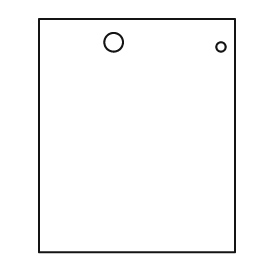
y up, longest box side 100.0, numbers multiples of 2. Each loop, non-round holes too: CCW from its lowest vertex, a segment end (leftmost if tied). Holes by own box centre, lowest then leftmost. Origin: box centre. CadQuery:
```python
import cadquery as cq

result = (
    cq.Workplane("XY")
    .moveTo(-42.0, -50.0)
    .lineTo(42.0, -50.0)
    .lineTo(42.0, 50.0)
    .lineTo(-42.0, 50.0)
    .close()
    .moveTo(36.0, 38.0)
    .circle(2.0)
    .moveTo(-10.0, 40.0)
    .circle(4.0)
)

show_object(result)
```